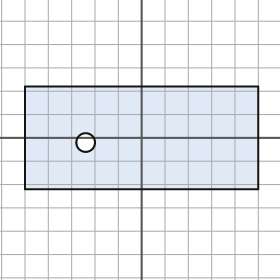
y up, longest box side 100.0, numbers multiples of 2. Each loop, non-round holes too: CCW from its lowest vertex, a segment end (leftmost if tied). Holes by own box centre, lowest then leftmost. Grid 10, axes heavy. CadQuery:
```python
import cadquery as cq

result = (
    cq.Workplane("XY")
    .moveTo(-50.0, -22.0)
    .lineTo(50.0, -22.0)
    .lineTo(50.0, 22.0)
    .lineTo(-50.0, 22.0)
    .close()
    .moveTo(-24.0, -2.0)
    .circle(4.0)
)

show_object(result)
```